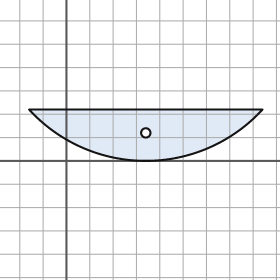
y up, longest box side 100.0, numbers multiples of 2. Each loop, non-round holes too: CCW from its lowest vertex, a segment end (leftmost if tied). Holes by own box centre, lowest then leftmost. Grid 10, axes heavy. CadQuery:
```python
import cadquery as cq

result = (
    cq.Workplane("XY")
    .moveTo(-16.0, 22.0)
    .threePointArc((34.0, 0.0), (84.0, 22.0))
    .close()
    .moveTo(34.0, 12.0)
    .circle(2.0)
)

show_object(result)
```